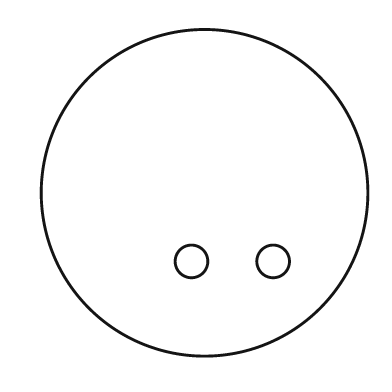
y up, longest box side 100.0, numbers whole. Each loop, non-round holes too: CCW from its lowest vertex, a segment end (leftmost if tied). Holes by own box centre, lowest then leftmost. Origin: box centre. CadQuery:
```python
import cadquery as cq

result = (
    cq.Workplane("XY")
    .moveTo(0.0, 0.0)
    .circle(50.0)
    .moveTo(-4.0, -21.0)
    .circle(5.0)
    .moveTo(21.0, -21.0)
    .circle(5.0)
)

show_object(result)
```